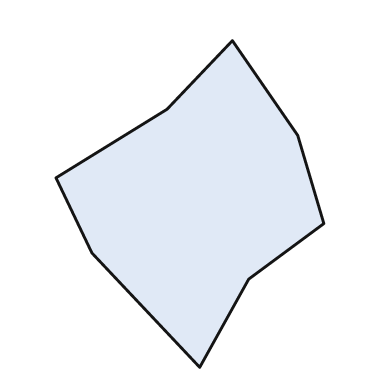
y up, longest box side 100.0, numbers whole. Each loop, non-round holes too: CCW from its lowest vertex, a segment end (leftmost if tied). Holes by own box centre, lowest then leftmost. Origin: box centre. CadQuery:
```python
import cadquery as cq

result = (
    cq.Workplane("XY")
    .moveTo(3.0, -50.0)
    .lineTo(18.0, -23.0)
    .lineTo(41.0, -6.0)
    .lineTo(33.0, 21.0)
    .lineTo(13.0, 50.0)
    .lineTo(-7.0, 29.0)
    .lineTo(-41.0, 8.0)
    .lineTo(-30.0, -15.0)
    .close()
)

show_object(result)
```